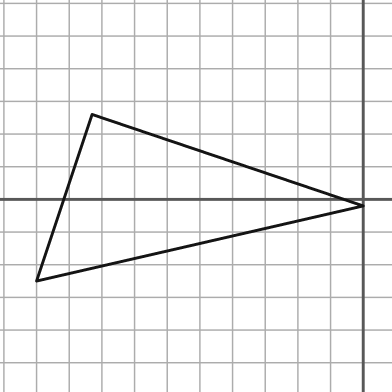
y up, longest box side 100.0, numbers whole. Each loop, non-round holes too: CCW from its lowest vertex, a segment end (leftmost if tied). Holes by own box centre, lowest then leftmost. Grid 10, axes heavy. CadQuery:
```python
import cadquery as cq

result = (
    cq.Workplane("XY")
    .moveTo(-100.0, -25.0)
    .lineTo(0.0, -2.0)
    .lineTo(-83.0, 26.0)
    .close()
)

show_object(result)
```